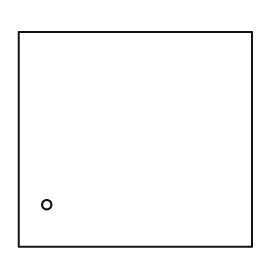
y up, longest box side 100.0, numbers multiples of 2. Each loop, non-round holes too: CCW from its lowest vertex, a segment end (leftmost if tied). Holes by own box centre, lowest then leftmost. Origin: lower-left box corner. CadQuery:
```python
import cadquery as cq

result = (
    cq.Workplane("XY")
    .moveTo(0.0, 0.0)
    .lineTo(100.0, 0.0)
    .lineTo(100.0, 92.0)
    .lineTo(0.0, 92.0)
    .close()
    .moveTo(12.0, 18.0)
    .circle(2.0)
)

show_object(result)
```